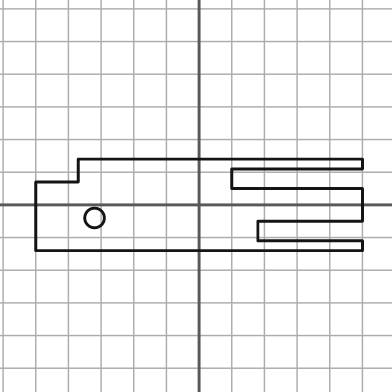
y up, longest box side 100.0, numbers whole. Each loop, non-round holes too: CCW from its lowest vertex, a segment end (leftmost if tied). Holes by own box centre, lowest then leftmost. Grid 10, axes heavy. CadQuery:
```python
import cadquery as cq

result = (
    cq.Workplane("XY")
    .moveTo(-50.0, -14.0)
    .lineTo(50.0, -14.0)
    .lineTo(50.0, -11.0)
    .lineTo(18.0, -11.0)
    .lineTo(18.0, -5.0)
    .lineTo(50.0, -5.0)
    .lineTo(50.0, 5.0)
    .lineTo(10.0, 5.0)
    .lineTo(10.0, 11.0)
    .lineTo(50.0, 11.0)
    .lineTo(50.0, 14.0)
    .lineTo(-37.0, 14.0)
    .lineTo(-37.0, 7.0)
    .lineTo(-50.0, 7.0)
    .close()
    .moveTo(-32.0, -4.0)
    .circle(3.0)
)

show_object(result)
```